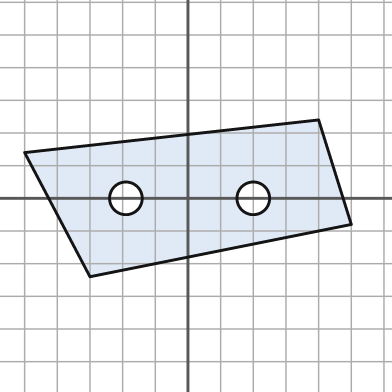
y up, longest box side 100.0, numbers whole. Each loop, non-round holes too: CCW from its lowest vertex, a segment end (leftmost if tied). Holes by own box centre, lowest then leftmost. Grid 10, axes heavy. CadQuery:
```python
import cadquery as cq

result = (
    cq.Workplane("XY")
    .moveTo(-30.0, -24.0)
    .lineTo(50.0, -8.0)
    .lineTo(40.0, 24.0)
    .lineTo(-50.0, 14.0)
    .close()
    .moveTo(-19.0, 0.0)
    .circle(5.0)
    .moveTo(20.0, 0.0)
    .circle(5.0)
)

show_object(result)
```